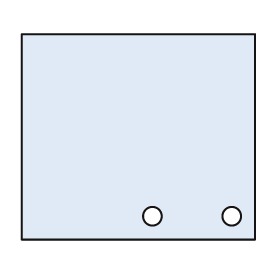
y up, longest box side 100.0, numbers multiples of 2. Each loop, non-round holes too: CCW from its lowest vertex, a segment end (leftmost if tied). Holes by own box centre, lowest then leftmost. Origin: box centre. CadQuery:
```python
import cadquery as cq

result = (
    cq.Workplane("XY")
    .moveTo(-50.0, -44.0)
    .lineTo(50.0, -44.0)
    .lineTo(50.0, 44.0)
    .lineTo(-50.0, 44.0)
    .close()
    .moveTo(6.0, -34.0)
    .circle(4.0)
    .moveTo(40.0, -34.0)
    .circle(4.0)
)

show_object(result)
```